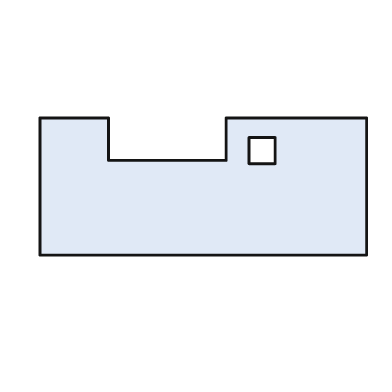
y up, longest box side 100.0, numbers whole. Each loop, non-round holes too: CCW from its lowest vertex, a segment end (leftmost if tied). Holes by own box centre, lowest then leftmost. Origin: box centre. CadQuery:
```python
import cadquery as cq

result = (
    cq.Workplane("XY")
    .moveTo(-50.0, -21.0)
    .lineTo(50.0, -21.0)
    .lineTo(50.0, 21.0)
    .lineTo(7.0, 21.0)
    .lineTo(7.0, 8.0)
    .lineTo(-29.0, 8.0)
    .lineTo(-29.0, 21.0)
    .lineTo(-50.0, 21.0)
    .close()
    .moveTo(14.0, 7.0)
    .lineTo(22.0, 7.0)
    .lineTo(22.0, 15.0)
    .lineTo(14.0, 15.0)
    .close()
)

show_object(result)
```